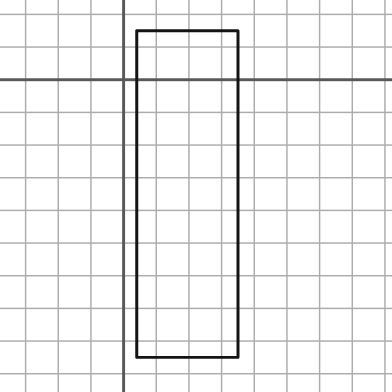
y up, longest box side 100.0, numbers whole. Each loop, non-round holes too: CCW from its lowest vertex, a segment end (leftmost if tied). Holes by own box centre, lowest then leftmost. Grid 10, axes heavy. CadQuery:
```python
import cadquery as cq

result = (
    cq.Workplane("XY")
    .moveTo(4.0, -85.0)
    .lineTo(35.0, -85.0)
    .lineTo(35.0, 15.0)
    .lineTo(4.0, 15.0)
    .close()
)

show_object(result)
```